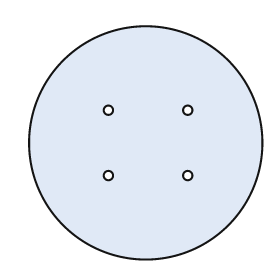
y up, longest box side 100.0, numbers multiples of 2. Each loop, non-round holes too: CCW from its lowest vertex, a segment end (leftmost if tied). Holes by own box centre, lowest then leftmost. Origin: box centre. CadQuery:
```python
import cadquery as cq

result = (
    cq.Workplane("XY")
    .moveTo(0.0, 0.0)
    .circle(50.0)
    .moveTo(-16.0, -14.0)
    .circle(2.0)
    .moveTo(18.0, -14.0)
    .circle(2.0)
    .moveTo(-16.0, 14.0)
    .circle(2.0)
    .moveTo(18.0, 14.0)
    .circle(2.0)
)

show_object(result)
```